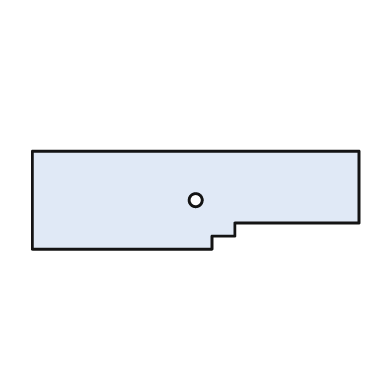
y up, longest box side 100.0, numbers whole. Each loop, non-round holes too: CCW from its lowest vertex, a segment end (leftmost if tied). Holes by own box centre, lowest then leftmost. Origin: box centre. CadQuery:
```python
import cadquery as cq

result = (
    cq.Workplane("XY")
    .moveTo(-50.0, -15.0)
    .lineTo(5.0, -15.0)
    .lineTo(5.0, -11.0)
    .lineTo(12.0, -11.0)
    .lineTo(12.0, -7.0)
    .lineTo(50.0, -7.0)
    .lineTo(50.0, 15.0)
    .lineTo(-50.0, 15.0)
    .close()
    .moveTo(0.0, 0.0)
    .circle(2.0)
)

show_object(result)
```